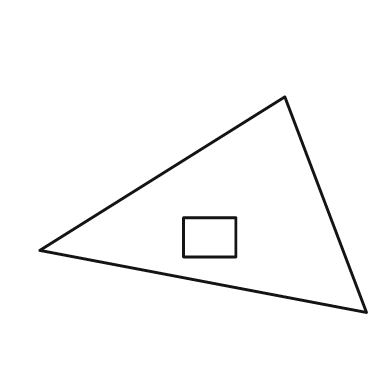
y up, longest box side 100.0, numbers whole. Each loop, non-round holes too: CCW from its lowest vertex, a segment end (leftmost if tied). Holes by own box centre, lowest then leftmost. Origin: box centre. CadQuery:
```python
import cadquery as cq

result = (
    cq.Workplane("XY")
    .moveTo(50.0, -33.0)
    .lineTo(25.0, 33.0)
    .lineTo(-50.0, -14.0)
    .close()
    .moveTo(-6.0, -16.0)
    .lineTo(10.0, -16.0)
    .lineTo(10.0, -4.0)
    .lineTo(-6.0, -4.0)
    .close()
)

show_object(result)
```